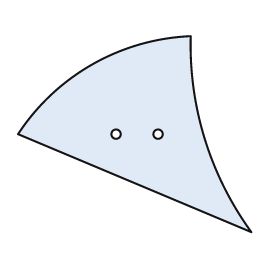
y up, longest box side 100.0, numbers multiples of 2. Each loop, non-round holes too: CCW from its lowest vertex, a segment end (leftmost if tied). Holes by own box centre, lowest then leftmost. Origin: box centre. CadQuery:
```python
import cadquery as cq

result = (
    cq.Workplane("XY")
    .moveTo(50.0, -42.0)
    .threePointArc((30.0, -2.0), (24.0, 42.0))
    .threePointArc((-18.0, 30.0), (-50.0, 0.0))
    .close()
    .moveTo(-8.0, 0.0)
    .circle(2.0)
    .moveTo(10.0, 0.0)
    .circle(2.0)
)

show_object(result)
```